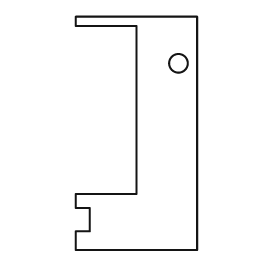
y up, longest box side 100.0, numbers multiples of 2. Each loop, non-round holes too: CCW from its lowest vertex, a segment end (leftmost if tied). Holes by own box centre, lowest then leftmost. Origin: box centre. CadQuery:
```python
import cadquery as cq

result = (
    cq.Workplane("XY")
    .moveTo(-26.0, -50.0)
    .lineTo(26.0, -50.0)
    .lineTo(26.0, 50.0)
    .lineTo(-26.0, 50.0)
    .lineTo(-26.0, 46.0)
    .lineTo(0.0, 46.0)
    .lineTo(0.0, -26.0)
    .lineTo(-26.0, -26.0)
    .lineTo(-26.0, -32.0)
    .lineTo(-20.0, -32.0)
    .lineTo(-20.0, -42.0)
    .lineTo(-26.0, -42.0)
    .close()
    .moveTo(18.0, 30.0)
    .circle(4.0)
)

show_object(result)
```